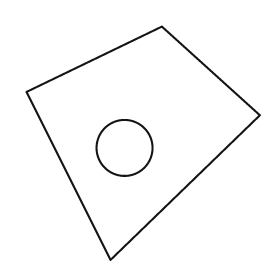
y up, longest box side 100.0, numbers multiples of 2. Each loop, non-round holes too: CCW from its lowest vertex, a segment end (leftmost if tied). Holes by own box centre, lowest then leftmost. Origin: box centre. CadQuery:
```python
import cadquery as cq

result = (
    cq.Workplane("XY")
    .moveTo(-14.0, -50.0)
    .lineTo(50.0, 12.0)
    .lineTo(8.0, 50.0)
    .lineTo(-50.0, 22.0)
    .close()
    .moveTo(-8.0, -2.0)
    .circle(12.0)
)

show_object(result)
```